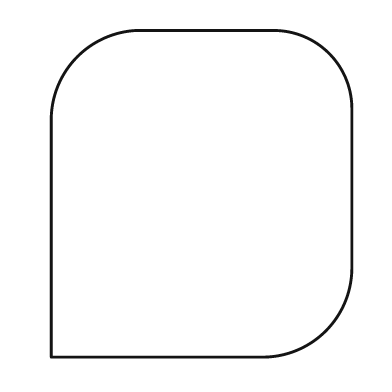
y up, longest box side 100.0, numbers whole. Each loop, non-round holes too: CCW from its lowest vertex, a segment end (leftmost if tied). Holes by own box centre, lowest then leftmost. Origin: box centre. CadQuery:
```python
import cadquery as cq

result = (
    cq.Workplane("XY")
    .moveTo(-46.0, -50.0)
    .lineTo(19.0, -50.0)
    .threePointArc((38.0, -42.0), (46.0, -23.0))
    .lineTo(46.0, 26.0)
    .threePointArc((39.0, 43.0), (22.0, 50.0))
    .lineTo(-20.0, 50.0)
    .threePointArc((-38.0, 42.0), (-46.0, 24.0))
    .close()
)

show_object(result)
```